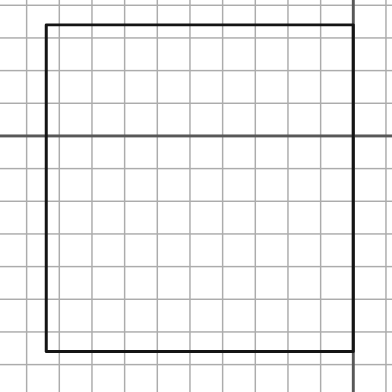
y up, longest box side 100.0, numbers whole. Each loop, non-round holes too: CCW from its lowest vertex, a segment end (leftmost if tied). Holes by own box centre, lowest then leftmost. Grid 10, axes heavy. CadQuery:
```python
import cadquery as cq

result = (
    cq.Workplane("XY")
    .moveTo(-94.0, -66.0)
    .lineTo(0.0, -66.0)
    .lineTo(0.0, 34.0)
    .lineTo(-94.0, 34.0)
    .close()
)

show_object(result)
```